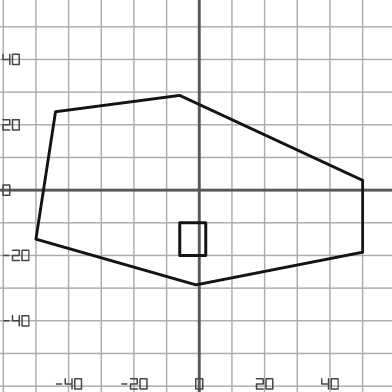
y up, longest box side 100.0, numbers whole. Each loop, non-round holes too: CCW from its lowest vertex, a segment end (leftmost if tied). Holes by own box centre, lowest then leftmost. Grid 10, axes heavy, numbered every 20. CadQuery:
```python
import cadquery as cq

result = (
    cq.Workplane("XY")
    .moveTo(-1.0, -29.0)
    .lineTo(50.0, -19.0)
    .lineTo(50.0, 3.0)
    .lineTo(-6.0, 29.0)
    .lineTo(-44.0, 24.0)
    .lineTo(-50.0, -15.0)
    .close()
    .moveTo(-6.0, -20.0)
    .lineTo(2.0, -20.0)
    .lineTo(2.0, -10.0)
    .lineTo(-6.0, -10.0)
    .close()
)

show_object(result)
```